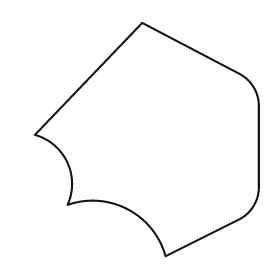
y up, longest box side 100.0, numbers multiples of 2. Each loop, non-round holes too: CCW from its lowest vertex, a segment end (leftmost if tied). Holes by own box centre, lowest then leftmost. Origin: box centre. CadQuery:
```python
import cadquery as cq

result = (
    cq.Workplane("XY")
    .moveTo(8.0, -50.0)
    .lineTo(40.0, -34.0)
    .threePointArc((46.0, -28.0), (48.0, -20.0))
    .lineTo(48.0, 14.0)
    .threePointArc((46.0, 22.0), (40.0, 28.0))
    .lineTo(-2.0, 50.0)
    .lineTo(-48.0, 2.0)
    .threePointArc((-34.0, -10.0), (-34.0, -28.0))
    .threePointArc((-8.0, -30.0), (8.0, -50.0))
    .close()
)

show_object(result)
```